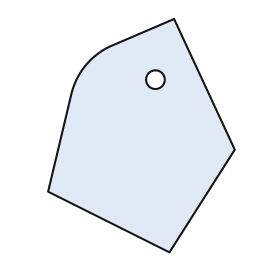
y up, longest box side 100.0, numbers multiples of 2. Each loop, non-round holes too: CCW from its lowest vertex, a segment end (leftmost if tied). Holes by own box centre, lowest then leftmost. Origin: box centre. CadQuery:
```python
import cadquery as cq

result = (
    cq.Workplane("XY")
    .moveTo(12.0, -50.0)
    .lineTo(40.0, -6.0)
    .lineTo(14.0, 50.0)
    .lineTo(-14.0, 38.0)
    .threePointArc((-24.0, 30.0), (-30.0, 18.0))
    .lineTo(-40.0, -24.0)
    .close()
    .moveTo(6.0, 24.0)
    .circle(4.0)
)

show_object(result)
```